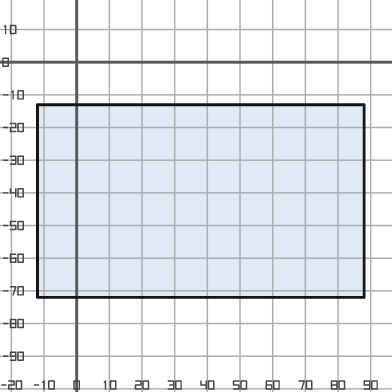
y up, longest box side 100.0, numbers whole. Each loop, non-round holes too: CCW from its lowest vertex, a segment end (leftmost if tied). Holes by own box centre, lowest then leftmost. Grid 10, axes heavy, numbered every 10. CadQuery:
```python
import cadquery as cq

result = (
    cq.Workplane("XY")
    .moveTo(-12.0, -72.0)
    .lineTo(88.0, -72.0)
    .lineTo(88.0, -13.0)
    .lineTo(-12.0, -13.0)
    .close()
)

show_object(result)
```